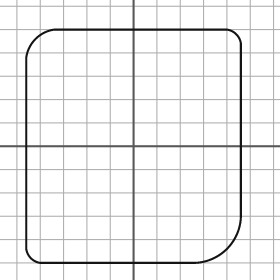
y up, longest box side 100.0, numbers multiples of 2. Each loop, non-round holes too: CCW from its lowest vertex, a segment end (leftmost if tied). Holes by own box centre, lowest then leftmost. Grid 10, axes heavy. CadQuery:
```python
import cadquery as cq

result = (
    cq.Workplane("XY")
    .moveTo(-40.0, -50.0)
    .lineTo(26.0, -50.0)
    .threePointArc((40.0, -44.0), (46.0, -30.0))
    .lineTo(46.0, 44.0)
    .threePointArc((44.0, 48.0), (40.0, 50.0))
    .lineTo(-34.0, 50.0)
    .threePointArc((-42.0, 46.0), (-46.0, 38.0))
    .lineTo(-46.0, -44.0)
    .threePointArc((-44.0, -48.0), (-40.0, -50.0))
    .close()
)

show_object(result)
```